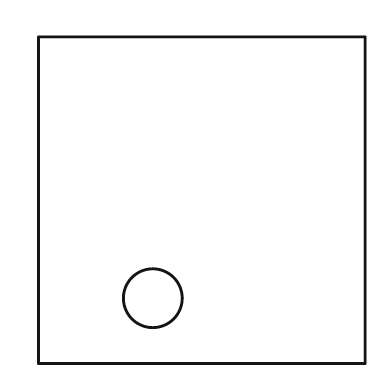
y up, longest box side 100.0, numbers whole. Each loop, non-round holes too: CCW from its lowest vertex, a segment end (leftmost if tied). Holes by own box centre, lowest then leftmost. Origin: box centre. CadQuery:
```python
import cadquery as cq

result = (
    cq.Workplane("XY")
    .moveTo(-50.0, -50.0)
    .lineTo(50.0, -50.0)
    .lineTo(50.0, 50.0)
    .lineTo(-50.0, 50.0)
    .close()
    .moveTo(-15.0, -30.0)
    .circle(9.0)
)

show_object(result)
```